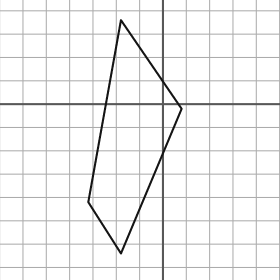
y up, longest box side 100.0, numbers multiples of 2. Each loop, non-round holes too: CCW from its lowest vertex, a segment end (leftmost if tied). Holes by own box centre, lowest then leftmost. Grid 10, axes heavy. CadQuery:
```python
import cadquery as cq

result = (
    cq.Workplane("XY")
    .moveTo(-18.0, -64.0)
    .lineTo(8.0, -2.0)
    .lineTo(-18.0, 36.0)
    .lineTo(-32.0, -42.0)
    .close()
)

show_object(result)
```